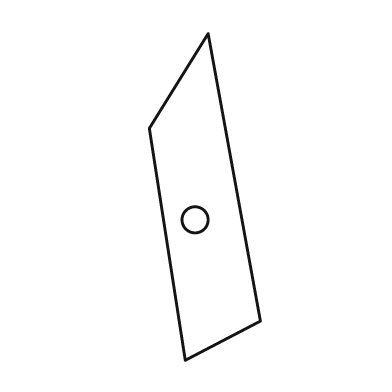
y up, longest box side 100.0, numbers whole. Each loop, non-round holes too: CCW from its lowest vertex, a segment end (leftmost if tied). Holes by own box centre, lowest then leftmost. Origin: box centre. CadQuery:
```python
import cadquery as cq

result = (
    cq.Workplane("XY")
    .moveTo(-6.0, -50.0)
    .lineTo(17.0, -38.0)
    .lineTo(1.0, 50.0)
    .lineTo(-17.0, 21.0)
    .close()
    .moveTo(-3.0, -7.0)
    .circle(4.0)
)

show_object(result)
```